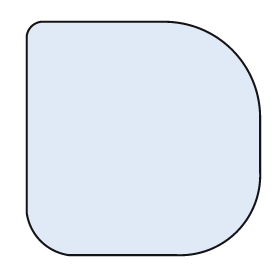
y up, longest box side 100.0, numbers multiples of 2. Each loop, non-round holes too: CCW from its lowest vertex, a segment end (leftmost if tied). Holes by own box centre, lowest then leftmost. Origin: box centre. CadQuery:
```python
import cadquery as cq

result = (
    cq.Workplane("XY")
    .moveTo(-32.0, -50.0)
    .lineTo(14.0, -50.0)
    .threePointArc((40.0, -40.0), (50.0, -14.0))
    .lineTo(50.0, 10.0)
    .threePointArc((38.0, 38.0), (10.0, 50.0))
    .lineTo(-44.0, 50.0)
    .threePointArc((-48.0, 48.0), (-50.0, 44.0))
    .lineTo(-50.0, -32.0)
    .threePointArc((-44.0, -44.0), (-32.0, -50.0))
    .close()
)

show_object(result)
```